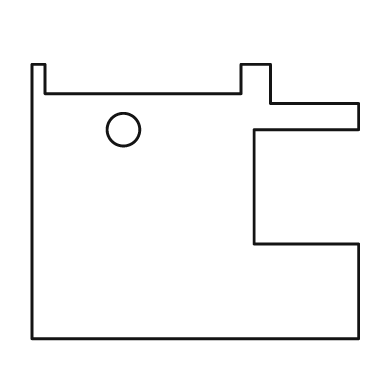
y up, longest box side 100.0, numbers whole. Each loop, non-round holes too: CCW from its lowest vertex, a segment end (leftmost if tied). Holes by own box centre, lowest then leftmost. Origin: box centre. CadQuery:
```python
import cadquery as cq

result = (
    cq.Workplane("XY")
    .moveTo(-50.0, -42.0)
    .lineTo(50.0, -42.0)
    .lineTo(50.0, -13.0)
    .lineTo(18.0, -13.0)
    .lineTo(18.0, 22.0)
    .lineTo(50.0, 22.0)
    .lineTo(50.0, 30.0)
    .lineTo(23.0, 30.0)
    .lineTo(23.0, 42.0)
    .lineTo(14.0, 42.0)
    .lineTo(14.0, 33.0)
    .lineTo(-46.0, 33.0)
    .lineTo(-46.0, 42.0)
    .lineTo(-50.0, 42.0)
    .close()
    .moveTo(-22.0, 22.0)
    .circle(5.0)
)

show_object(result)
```